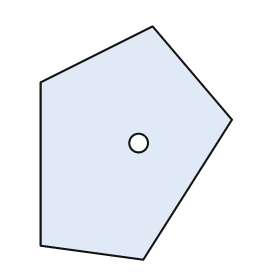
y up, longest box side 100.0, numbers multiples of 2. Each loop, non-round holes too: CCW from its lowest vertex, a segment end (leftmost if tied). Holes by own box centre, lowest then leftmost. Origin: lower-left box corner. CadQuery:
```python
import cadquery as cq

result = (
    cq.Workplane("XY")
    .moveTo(44.0, 0.0)
    .lineTo(82.0, 60.0)
    .lineTo(48.0, 100.0)
    .lineTo(0.0, 76.0)
    .lineTo(0.0, 6.0)
    .close()
    .moveTo(42.0, 50.0)
    .circle(4.0)
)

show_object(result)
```